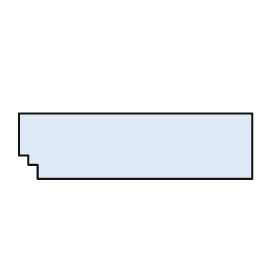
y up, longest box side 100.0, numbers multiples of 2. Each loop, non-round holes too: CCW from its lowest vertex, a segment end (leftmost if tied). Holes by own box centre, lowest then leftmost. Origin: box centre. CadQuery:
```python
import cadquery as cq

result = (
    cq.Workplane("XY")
    .moveTo(-42.0, -14.0)
    .lineTo(50.0, -14.0)
    .lineTo(50.0, 14.0)
    .lineTo(-50.0, 14.0)
    .lineTo(-50.0, -4.0)
    .lineTo(-46.0, -4.0)
    .lineTo(-46.0, -8.0)
    .lineTo(-42.0, -8.0)
    .close()
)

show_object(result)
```